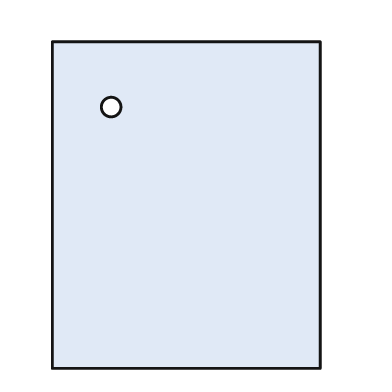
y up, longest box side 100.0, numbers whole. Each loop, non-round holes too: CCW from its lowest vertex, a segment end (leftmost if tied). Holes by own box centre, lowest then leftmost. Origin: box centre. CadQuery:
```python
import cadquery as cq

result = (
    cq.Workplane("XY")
    .moveTo(-41.0, -50.0)
    .lineTo(41.0, -50.0)
    .lineTo(41.0, 50.0)
    .lineTo(-41.0, 50.0)
    .close()
    .moveTo(-23.0, 30.0)
    .circle(3.0)
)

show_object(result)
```